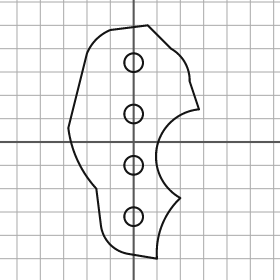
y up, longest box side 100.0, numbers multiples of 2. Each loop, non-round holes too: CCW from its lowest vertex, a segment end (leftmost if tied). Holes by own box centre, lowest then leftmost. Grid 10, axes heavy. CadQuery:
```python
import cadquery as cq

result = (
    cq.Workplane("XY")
    .moveTo(10.0, -50.0)
    .threePointArc((12.0, -36.0), (20.0, -24.0))
    .threePointArc((10.0, -2.0), (28.0, 14.0))
    .lineTo(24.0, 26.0)
    .threePointArc((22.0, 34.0), (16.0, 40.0))
    .lineTo(6.0, 50.0)
    .lineTo(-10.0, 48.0)
    .threePointArc((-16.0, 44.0), (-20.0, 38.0))
    .lineTo(-28.0, 6.0)
    .threePointArc((-24.0, -8.0), (-16.0, -20.0))
    .lineTo(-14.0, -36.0)
    .threePointArc((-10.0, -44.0), (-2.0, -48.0))
    .close()
    .moveTo(0.0, -32.0)
    .circle(4.0)
    .moveTo(0.0, -10.0)
    .circle(4.0)
    .moveTo(0.0, 12.0)
    .circle(4.0)
    .moveTo(0.0, 34.0)
    .circle(4.0)
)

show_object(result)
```